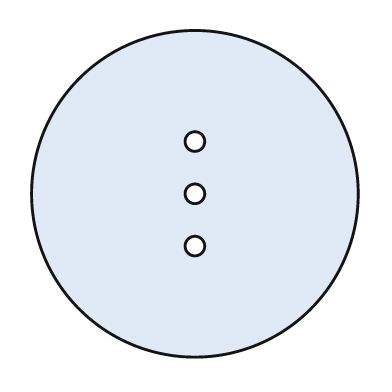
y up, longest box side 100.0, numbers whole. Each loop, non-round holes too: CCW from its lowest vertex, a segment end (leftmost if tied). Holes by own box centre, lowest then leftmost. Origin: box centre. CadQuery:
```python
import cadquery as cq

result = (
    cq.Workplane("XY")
    .moveTo(0.0, 0.0)
    .circle(50.0)
    .moveTo(0.0, -16.0)
    .circle(3.0)
    .moveTo(0.0, 0.0)
    .circle(3.0)
    .moveTo(0.0, 16.0)
    .circle(3.0)
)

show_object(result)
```